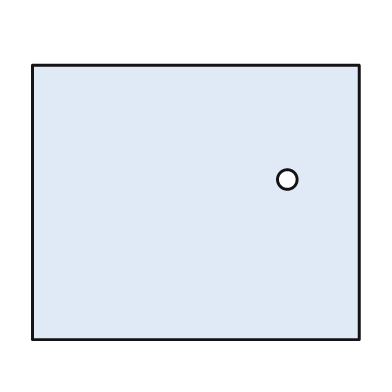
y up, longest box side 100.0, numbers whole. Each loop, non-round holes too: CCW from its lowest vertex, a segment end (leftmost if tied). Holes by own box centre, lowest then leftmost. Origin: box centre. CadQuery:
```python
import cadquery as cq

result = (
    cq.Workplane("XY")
    .moveTo(-50.0, -42.0)
    .lineTo(50.0, -42.0)
    .lineTo(50.0, 42.0)
    .lineTo(-50.0, 42.0)
    .close()
    .moveTo(28.0, 7.0)
    .circle(3.0)
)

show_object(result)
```